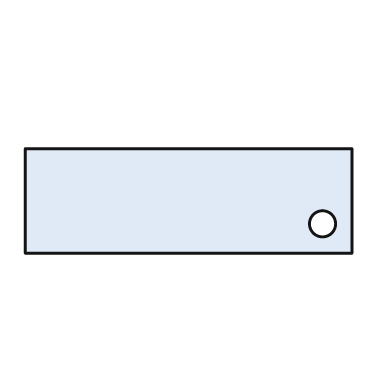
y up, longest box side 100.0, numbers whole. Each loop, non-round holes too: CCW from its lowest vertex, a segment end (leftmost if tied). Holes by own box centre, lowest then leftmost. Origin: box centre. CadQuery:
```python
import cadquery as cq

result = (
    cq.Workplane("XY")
    .moveTo(-50.0, -16.0)
    .lineTo(50.0, -16.0)
    .lineTo(50.0, 16.0)
    .lineTo(-50.0, 16.0)
    .close()
    .moveTo(41.0, -7.0)
    .circle(4.0)
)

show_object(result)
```